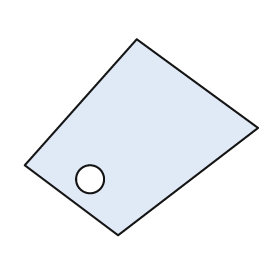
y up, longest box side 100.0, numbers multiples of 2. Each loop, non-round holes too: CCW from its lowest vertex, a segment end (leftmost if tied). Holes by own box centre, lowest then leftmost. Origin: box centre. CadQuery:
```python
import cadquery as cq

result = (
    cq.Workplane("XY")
    .moveTo(-10.0, -42.0)
    .lineTo(50.0, 4.0)
    .lineTo(-2.0, 42.0)
    .lineTo(-50.0, -12.0)
    .close()
    .moveTo(-22.0, -18.0)
    .circle(6.0)
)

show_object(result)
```